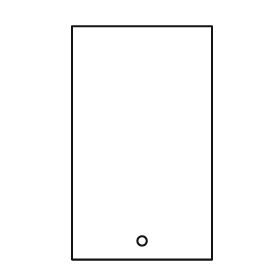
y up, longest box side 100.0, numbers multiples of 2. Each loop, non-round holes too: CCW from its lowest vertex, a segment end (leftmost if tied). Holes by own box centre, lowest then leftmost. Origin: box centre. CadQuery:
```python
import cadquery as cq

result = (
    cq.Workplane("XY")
    .moveTo(-30.0, -50.0)
    .lineTo(30.0, -50.0)
    .lineTo(30.0, 50.0)
    .lineTo(-30.0, 50.0)
    .close()
    .moveTo(0.0, -42.0)
    .circle(2.0)
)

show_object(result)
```